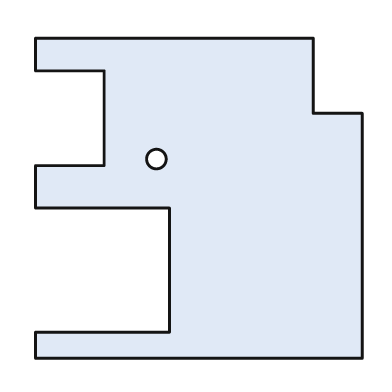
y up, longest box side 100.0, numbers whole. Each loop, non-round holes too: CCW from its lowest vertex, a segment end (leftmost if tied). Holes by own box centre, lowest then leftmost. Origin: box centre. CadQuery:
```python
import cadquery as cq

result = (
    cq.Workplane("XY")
    .moveTo(-50.0, -49.0)
    .lineTo(50.0, -49.0)
    .lineTo(50.0, 26.0)
    .lineTo(35.0, 26.0)
    .lineTo(35.0, 49.0)
    .lineTo(-50.0, 49.0)
    .lineTo(-50.0, 39.0)
    .lineTo(-29.0, 39.0)
    .lineTo(-29.0, 10.0)
    .lineTo(-50.0, 10.0)
    .lineTo(-50.0, -3.0)
    .lineTo(-9.0, -3.0)
    .lineTo(-9.0, -41.0)
    .lineTo(-50.0, -41.0)
    .close()
    .moveTo(-13.0, 12.0)
    .circle(3.0)
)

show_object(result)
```